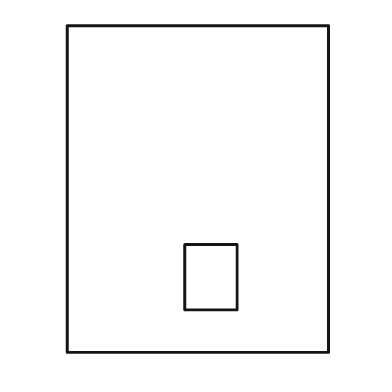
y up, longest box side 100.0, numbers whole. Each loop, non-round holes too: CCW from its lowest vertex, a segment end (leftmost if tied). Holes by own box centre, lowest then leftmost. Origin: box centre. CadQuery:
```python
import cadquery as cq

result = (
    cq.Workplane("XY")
    .moveTo(-40.0, -50.0)
    .lineTo(40.0, -50.0)
    .lineTo(40.0, 50.0)
    .lineTo(-40.0, 50.0)
    .close()
    .moveTo(-4.0, -37.0)
    .lineTo(12.0, -37.0)
    .lineTo(12.0, -17.0)
    .lineTo(-4.0, -17.0)
    .close()
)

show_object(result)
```